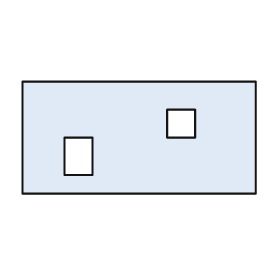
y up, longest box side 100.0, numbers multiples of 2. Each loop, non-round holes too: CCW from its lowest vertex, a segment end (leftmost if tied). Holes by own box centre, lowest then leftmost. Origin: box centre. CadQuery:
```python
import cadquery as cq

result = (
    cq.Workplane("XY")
    .moveTo(-50.0, -24.0)
    .lineTo(50.0, -24.0)
    .lineTo(50.0, 24.0)
    .lineTo(-50.0, 24.0)
    .close()
    .moveTo(-32.0, -16.0)
    .lineTo(-20.0, -16.0)
    .lineTo(-20.0, 0.0)
    .lineTo(-32.0, 0.0)
    .close()
    .moveTo(12.0, 0.0)
    .lineTo(24.0, 0.0)
    .lineTo(24.0, 12.0)
    .lineTo(12.0, 12.0)
    .close()
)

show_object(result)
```